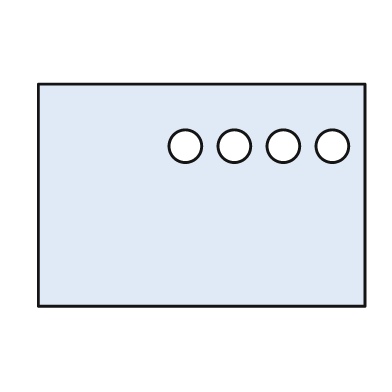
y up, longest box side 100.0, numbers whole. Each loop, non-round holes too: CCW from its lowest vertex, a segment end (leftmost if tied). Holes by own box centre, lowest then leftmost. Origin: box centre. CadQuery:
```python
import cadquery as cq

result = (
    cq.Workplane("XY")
    .moveTo(-50.0, -34.0)
    .lineTo(50.0, -34.0)
    .lineTo(50.0, 34.0)
    .lineTo(-50.0, 34.0)
    .close()
    .moveTo(-5.0, 15.0)
    .circle(5.0)
    .moveTo(10.0, 15.0)
    .circle(5.0)
    .moveTo(25.0, 15.0)
    .circle(5.0)
    .moveTo(40.0, 15.0)
    .circle(5.0)
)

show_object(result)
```